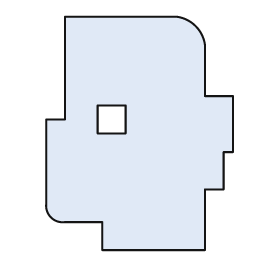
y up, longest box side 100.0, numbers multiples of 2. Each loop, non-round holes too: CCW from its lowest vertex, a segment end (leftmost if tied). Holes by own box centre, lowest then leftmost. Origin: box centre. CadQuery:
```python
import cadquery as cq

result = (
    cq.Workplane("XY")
    .moveTo(-16.0, -50.0)
    .lineTo(28.0, -50.0)
    .lineTo(28.0, -24.0)
    .lineTo(36.0, -24.0)
    .lineTo(36.0, -8.0)
    .lineTo(40.0, -8.0)
    .lineTo(40.0, 16.0)
    .lineTo(28.0, 16.0)
    .lineTo(28.0, 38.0)
    .threePointArc((24.0, 46.0), (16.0, 50.0))
    .lineTo(-32.0, 50.0)
    .lineTo(-32.0, 6.0)
    .lineTo(-40.0, 6.0)
    .lineTo(-40.0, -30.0)
    .threePointArc((-38.0, -36.0), (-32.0, -38.0))
    .lineTo(-16.0, -38.0)
    .close()
    .moveTo(-18.0, 0.0)
    .lineTo(-6.0, 0.0)
    .lineTo(-6.0, 12.0)
    .lineTo(-18.0, 12.0)
    .close()
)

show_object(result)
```